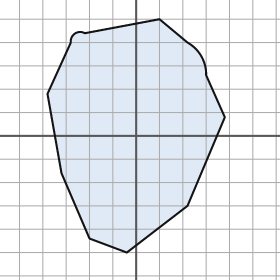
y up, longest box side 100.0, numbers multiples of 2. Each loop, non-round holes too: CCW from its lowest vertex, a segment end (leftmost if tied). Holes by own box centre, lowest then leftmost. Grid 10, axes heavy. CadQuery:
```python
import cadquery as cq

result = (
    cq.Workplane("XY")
    .moveTo(-4.0, -50.0)
    .lineTo(22.0, -30.0)
    .lineTo(38.0, 8.0)
    .lineTo(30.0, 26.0)
    .threePointArc((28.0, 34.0), (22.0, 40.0))
    .lineTo(10.0, 50.0)
    .lineTo(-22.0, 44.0)
    .threePointArc((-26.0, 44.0), (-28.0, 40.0))
    .lineTo(-38.0, 18.0)
    .lineTo(-32.0, -16.0)
    .lineTo(-20.0, -44.0)
    .close()
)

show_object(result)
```